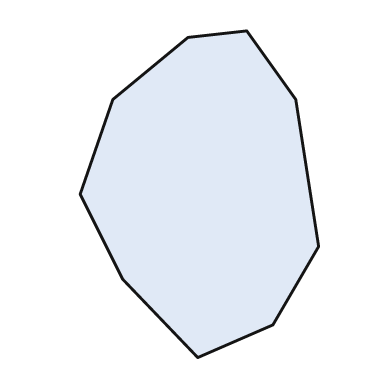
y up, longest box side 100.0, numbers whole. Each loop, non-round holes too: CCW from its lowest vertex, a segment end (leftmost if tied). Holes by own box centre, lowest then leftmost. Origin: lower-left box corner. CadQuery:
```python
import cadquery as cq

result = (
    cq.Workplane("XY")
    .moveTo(36.0, 0.0)
    .lineTo(59.0, 10.0)
    .lineTo(73.0, 34.0)
    .lineTo(66.0, 79.0)
    .lineTo(51.0, 100.0)
    .lineTo(33.0, 98.0)
    .lineTo(10.0, 79.0)
    .lineTo(0.0, 50.0)
    .lineTo(13.0, 24.0)
    .close()
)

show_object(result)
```